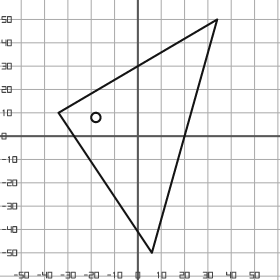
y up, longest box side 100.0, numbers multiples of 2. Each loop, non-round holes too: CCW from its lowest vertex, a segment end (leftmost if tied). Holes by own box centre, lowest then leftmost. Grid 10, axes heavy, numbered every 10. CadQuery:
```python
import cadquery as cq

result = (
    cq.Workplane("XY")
    .moveTo(6.0, -50.0)
    .lineTo(34.0, 50.0)
    .lineTo(-34.0, 10.0)
    .close()
    .moveTo(-18.0, 8.0)
    .circle(2.0)
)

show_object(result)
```